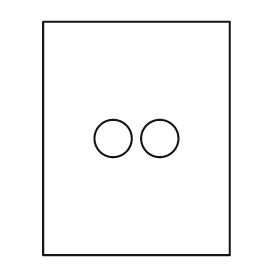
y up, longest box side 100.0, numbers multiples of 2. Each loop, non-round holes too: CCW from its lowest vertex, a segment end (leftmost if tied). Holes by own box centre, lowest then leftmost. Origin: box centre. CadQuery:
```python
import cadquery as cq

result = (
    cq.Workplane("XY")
    .moveTo(-40.0, -50.0)
    .lineTo(40.0, -50.0)
    .lineTo(40.0, 50.0)
    .lineTo(-40.0, 50.0)
    .close()
    .moveTo(-10.0, 0.0)
    .circle(8.0)
    .moveTo(10.0, 0.0)
    .circle(8.0)
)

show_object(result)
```